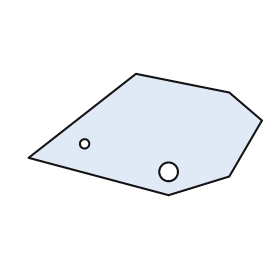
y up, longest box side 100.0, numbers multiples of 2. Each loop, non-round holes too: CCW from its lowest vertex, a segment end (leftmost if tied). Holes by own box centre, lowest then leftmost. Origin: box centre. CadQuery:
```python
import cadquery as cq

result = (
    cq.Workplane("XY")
    .moveTo(10.0, -26.0)
    .lineTo(36.0, -18.0)
    .lineTo(50.0, 6.0)
    .lineTo(36.0, 18.0)
    .lineTo(-4.0, 26.0)
    .lineTo(-50.0, -10.0)
    .close()
    .moveTo(10.0, -16.0)
    .circle(4.0)
    .moveTo(-26.0, -4.0)
    .circle(2.0)
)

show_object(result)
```